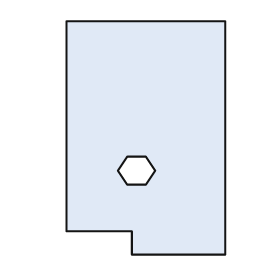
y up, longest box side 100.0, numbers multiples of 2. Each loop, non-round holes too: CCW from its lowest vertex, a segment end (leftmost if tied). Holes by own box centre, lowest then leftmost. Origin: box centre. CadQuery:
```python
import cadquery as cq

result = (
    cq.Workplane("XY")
    .moveTo(-6.0, -50.0)
    .lineTo(34.0, -50.0)
    .lineTo(34.0, 50.0)
    .lineTo(-34.0, 50.0)
    .lineTo(-34.0, -40.0)
    .lineTo(-6.0, -40.0)
    .close()
    .moveTo(-8.0, -20.0)
    .lineTo(0.0, -20.0)
    .lineTo(4.0, -14.0)
    .lineTo(0.0, -8.0)
    .lineTo(-8.0, -8.0)
    .lineTo(-12.0, -14.0)
    .close()
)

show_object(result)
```